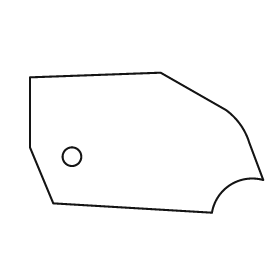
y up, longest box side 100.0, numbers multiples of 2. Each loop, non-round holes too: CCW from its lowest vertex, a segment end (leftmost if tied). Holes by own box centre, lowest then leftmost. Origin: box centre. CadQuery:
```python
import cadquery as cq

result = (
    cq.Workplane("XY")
    .moveTo(28.0, -30.0)
    .threePointArc((36.0, -18.0), (50.0, -16.0))
    .lineTo(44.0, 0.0)
    .threePointArc((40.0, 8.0), (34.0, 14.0))
    .lineTo(6.0, 30.0)
    .lineTo(-50.0, 28.0)
    .lineTo(-50.0, -2.0)
    .lineTo(-40.0, -26.0)
    .close()
    .moveTo(-32.0, -6.0)
    .circle(4.0)
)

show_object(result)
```